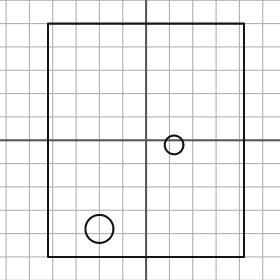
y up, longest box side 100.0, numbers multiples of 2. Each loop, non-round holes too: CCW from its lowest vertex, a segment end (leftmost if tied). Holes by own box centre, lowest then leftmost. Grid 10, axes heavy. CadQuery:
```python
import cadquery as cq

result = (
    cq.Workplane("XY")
    .moveTo(-42.0, -50.0)
    .lineTo(42.0, -50.0)
    .lineTo(42.0, 50.0)
    .lineTo(-42.0, 50.0)
    .close()
    .moveTo(-20.0, -38.0)
    .circle(6.0)
    .moveTo(12.0, -2.0)
    .circle(4.0)
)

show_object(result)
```